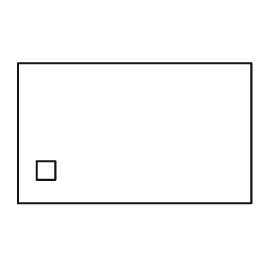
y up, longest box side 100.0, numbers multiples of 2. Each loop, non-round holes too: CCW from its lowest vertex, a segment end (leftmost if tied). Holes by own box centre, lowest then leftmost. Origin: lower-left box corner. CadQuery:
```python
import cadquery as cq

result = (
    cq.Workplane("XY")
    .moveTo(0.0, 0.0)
    .lineTo(100.0, 0.0)
    .lineTo(100.0, 60.0)
    .lineTo(0.0, 60.0)
    .close()
    .moveTo(8.0, 10.0)
    .lineTo(16.0, 10.0)
    .lineTo(16.0, 18.0)
    .lineTo(8.0, 18.0)
    .close()
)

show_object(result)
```